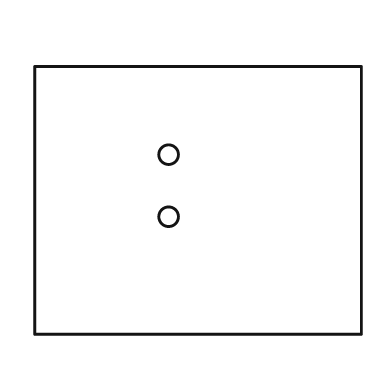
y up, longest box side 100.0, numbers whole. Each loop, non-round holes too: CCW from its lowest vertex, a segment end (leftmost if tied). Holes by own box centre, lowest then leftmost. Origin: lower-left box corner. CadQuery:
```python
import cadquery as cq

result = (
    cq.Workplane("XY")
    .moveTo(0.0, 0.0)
    .lineTo(100.0, 0.0)
    .lineTo(100.0, 82.0)
    .lineTo(0.0, 82.0)
    .close()
    .moveTo(41.0, 36.0)
    .circle(3.0)
    .moveTo(41.0, 55.0)
    .circle(3.0)
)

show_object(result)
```